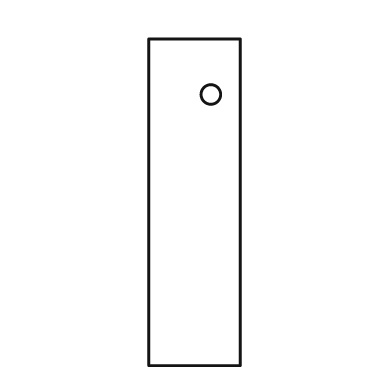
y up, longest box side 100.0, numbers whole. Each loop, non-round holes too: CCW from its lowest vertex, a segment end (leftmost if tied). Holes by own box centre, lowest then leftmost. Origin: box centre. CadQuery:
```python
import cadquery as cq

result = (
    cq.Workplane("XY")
    .moveTo(-14.0, -50.0)
    .lineTo(14.0, -50.0)
    .lineTo(14.0, 50.0)
    .lineTo(-14.0, 50.0)
    .close()
    .moveTo(5.0, 33.0)
    .circle(3.0)
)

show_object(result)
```